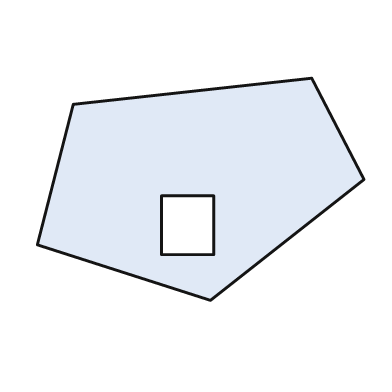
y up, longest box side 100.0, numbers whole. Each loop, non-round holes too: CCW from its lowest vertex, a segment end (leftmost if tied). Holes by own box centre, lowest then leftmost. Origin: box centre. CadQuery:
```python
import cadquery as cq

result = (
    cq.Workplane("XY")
    .moveTo(3.0, -34.0)
    .lineTo(50.0, 3.0)
    .lineTo(34.0, 34.0)
    .lineTo(-39.0, 26.0)
    .lineTo(-50.0, -17.0)
    .close()
    .moveTo(-12.0, -20.0)
    .lineTo(4.0, -20.0)
    .lineTo(4.0, -2.0)
    .lineTo(-12.0, -2.0)
    .close()
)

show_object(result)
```